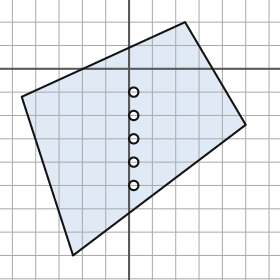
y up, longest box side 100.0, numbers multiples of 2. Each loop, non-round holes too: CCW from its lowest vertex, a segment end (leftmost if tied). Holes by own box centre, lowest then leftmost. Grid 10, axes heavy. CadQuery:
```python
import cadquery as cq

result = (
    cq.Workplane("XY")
    .moveTo(-24.0, -80.0)
    .lineTo(50.0, -24.0)
    .lineTo(24.0, 20.0)
    .lineTo(-46.0, -12.0)
    .close()
    .moveTo(2.0, -50.0)
    .circle(2.0)
    .moveTo(2.0, -40.0)
    .circle(2.0)
    .moveTo(2.0, -30.0)
    .circle(2.0)
    .moveTo(2.0, -20.0)
    .circle(2.0)
    .moveTo(2.0, -10.0)
    .circle(2.0)
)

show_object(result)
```